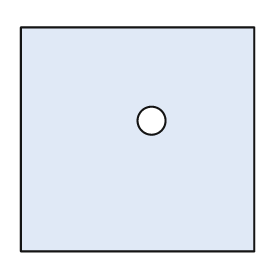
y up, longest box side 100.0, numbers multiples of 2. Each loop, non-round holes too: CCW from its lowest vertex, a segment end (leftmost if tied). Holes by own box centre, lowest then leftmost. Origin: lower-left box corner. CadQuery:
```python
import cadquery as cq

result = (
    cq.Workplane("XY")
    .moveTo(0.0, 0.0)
    .lineTo(100.0, 0.0)
    .lineTo(100.0, 96.0)
    .lineTo(0.0, 96.0)
    .close()
    .moveTo(56.0, 56.0)
    .circle(6.0)
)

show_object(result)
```